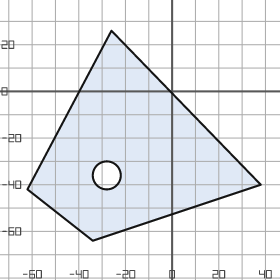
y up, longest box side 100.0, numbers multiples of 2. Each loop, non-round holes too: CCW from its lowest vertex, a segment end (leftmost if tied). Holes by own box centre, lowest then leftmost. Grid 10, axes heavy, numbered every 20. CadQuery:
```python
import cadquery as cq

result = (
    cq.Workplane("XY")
    .moveTo(-34.0, -64.0)
    .lineTo(38.0, -40.0)
    .lineTo(-26.0, 26.0)
    .lineTo(-62.0, -42.0)
    .close()
    .moveTo(-28.0, -36.0)
    .circle(6.0)
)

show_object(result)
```